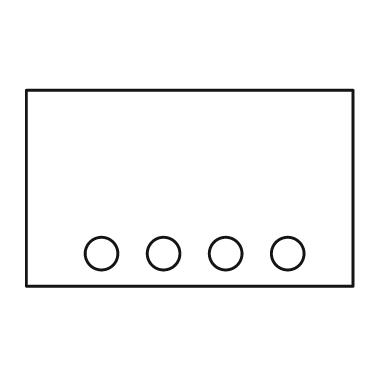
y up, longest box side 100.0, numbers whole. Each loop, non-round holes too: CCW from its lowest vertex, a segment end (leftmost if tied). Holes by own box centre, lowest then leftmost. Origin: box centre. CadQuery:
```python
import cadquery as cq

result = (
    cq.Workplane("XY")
    .moveTo(-50.0, -30.0)
    .lineTo(50.0, -30.0)
    .lineTo(50.0, 30.0)
    .lineTo(-50.0, 30.0)
    .close()
    .moveTo(-27.0, -20.0)
    .circle(5.0)
    .moveTo(-8.0, -20.0)
    .circle(5.0)
    .moveTo(11.0, -20.0)
    .circle(5.0)
    .moveTo(30.0, -20.0)
    .circle(5.0)
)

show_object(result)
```